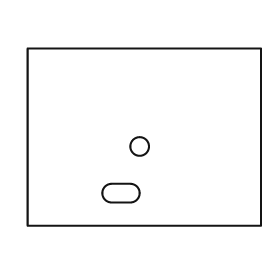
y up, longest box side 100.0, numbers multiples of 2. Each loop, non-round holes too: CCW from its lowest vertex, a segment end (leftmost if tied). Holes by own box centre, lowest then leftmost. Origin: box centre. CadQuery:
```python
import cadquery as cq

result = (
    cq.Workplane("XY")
    .moveTo(-50.0, -38.0)
    .lineTo(50.0, -38.0)
    .lineTo(50.0, 38.0)
    .lineTo(-50.0, 38.0)
    .close()
    .moveTo(-14.0, -28.0)
    .lineTo(-6.0, -28.0)
    .threePointArc((-2.0, -24.0), (-6.0, -20.0))
    .lineTo(-14.0, -20.0)
    .threePointArc((-18.0, -24.0), (-14.0, -28.0))
    .close()
    .moveTo(-2.0, -4.0)
    .circle(4.0)
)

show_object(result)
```